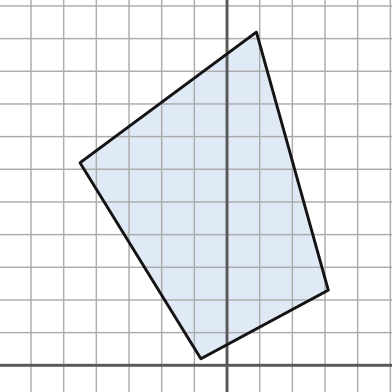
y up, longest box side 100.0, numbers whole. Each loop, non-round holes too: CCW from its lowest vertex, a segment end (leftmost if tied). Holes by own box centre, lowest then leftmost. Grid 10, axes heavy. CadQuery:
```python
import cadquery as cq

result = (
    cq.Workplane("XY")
    .moveTo(-8.0, 2.0)
    .lineTo(31.0, 23.0)
    .lineTo(9.0, 102.0)
    .lineTo(-45.0, 62.0)
    .close()
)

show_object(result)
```